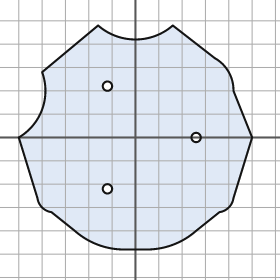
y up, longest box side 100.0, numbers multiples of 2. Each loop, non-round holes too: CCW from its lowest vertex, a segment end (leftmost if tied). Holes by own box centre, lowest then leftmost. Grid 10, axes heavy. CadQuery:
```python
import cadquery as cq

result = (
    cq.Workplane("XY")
    .moveTo(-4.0, -48.0)
    .lineTo(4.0, -48.0)
    .threePointArc((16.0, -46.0), (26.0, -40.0))
    .lineTo(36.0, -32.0)
    .threePointArc((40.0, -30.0), (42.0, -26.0))
    .lineTo(50.0, 0.0)
    .lineTo(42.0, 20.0)
    .threePointArc((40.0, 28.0), (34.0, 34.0))
    .lineTo(16.0, 48.0)
    .threePointArc((0.0, 42.0), (-16.0, 48.0))
    .lineTo(-40.0, 28.0)
    .threePointArc((-40.0, 12.0), (-50.0, 0.0))
    .lineTo(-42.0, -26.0)
    .threePointArc((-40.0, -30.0), (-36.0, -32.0))
    .lineTo(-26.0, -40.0)
    .threePointArc((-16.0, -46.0), (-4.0, -48.0))
    .close()
    .moveTo(-12.0, -22.0)
    .circle(2.0)
    .moveTo(26.0, 0.0)
    .circle(2.0)
    .moveTo(-12.0, 22.0)
    .circle(2.0)
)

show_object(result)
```